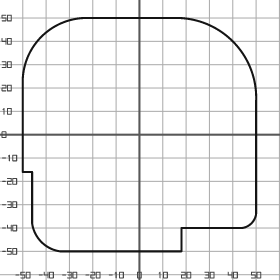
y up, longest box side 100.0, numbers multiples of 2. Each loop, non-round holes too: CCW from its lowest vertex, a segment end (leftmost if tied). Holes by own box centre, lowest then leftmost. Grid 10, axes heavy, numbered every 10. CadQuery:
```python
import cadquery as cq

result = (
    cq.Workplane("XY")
    .moveTo(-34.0, -50.0)
    .lineTo(18.0, -50.0)
    .lineTo(18.0, -40.0)
    .lineTo(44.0, -40.0)
    .threePointArc((48.0, -38.0), (50.0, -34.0))
    .lineTo(50.0, 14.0)
    .threePointArc((40.0, 40.0), (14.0, 50.0))
    .lineTo(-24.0, 50.0)
    .threePointArc((-42.0, 42.0), (-50.0, 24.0))
    .lineTo(-50.0, -16.0)
    .lineTo(-46.0, -16.0)
    .lineTo(-46.0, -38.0)
    .threePointArc((-42.0, -46.0), (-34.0, -50.0))
    .close()
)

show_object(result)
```